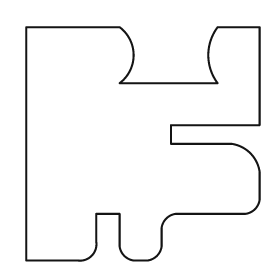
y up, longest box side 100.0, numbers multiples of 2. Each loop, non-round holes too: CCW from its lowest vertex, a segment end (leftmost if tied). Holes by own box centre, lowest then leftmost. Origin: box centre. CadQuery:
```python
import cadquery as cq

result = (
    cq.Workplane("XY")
    .moveTo(-50.0, -50.0)
    .lineTo(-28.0, -50.0)
    .threePointArc((-22.0, -48.0), (-20.0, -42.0))
    .lineTo(-20.0, -30.0)
    .lineTo(-10.0, -30.0)
    .lineTo(-10.0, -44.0)
    .threePointArc((-8.0, -48.0), (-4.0, -50.0))
    .lineTo(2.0, -50.0)
    .threePointArc((6.0, -48.0), (8.0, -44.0))
    .lineTo(8.0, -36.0)
    .threePointArc((10.0, -32.0), (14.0, -30.0))
    .lineTo(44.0, -30.0)
    .threePointArc((48.0, -28.0), (50.0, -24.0))
    .lineTo(50.0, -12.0)
    .threePointArc((46.0, -4.0), (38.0, 0.0))
    .lineTo(12.0, 0.0)
    .lineTo(12.0, 8.0)
    .lineTo(50.0, 8.0)
    .lineTo(50.0, 50.0)
    .lineTo(32.0, 50.0)
    .threePointArc((28.0, 38.0), (32.0, 26.0))
    .lineTo(-10.0, 26.0)
    .threePointArc((-4.0, 38.0), (-10.0, 50.0))
    .lineTo(-50.0, 50.0)
    .close()
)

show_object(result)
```